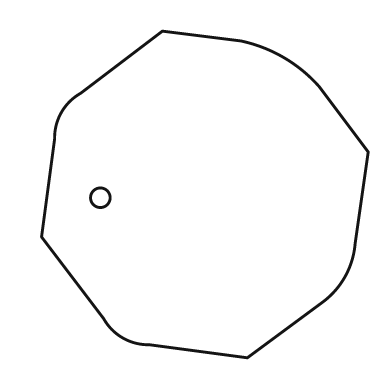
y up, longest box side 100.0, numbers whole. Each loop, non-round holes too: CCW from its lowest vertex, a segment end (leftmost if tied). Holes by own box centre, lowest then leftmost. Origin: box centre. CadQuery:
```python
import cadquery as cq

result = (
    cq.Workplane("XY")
    .moveTo(13.0, -50.0)
    .lineTo(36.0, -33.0)
    .threePointArc((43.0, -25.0), (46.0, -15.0))
    .lineTo(50.0, 13.0)
    .lineTo(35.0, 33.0)
    .threePointArc((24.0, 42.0), (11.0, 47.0))
    .lineTo(-13.0, 50.0)
    .lineTo(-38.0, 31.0)
    .threePointArc((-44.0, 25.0), (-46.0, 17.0))
    .lineTo(-50.0, -13.0)
    .lineTo(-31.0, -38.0)
    .threePointArc((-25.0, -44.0), (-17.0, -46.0))
    .close()
    .moveTo(-32.0, -1.0)
    .circle(3.0)
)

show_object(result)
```